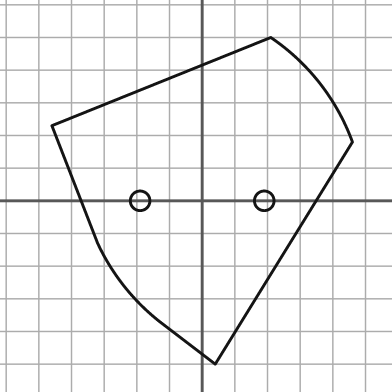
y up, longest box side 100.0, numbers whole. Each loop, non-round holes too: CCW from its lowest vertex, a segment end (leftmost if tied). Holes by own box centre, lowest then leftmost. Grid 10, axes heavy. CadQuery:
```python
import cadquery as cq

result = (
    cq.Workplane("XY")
    .moveTo(4.0, -50.0)
    .lineTo(46.0, 18.0)
    .threePointArc((36.0, 36.0), (21.0, 50.0))
    .lineTo(-46.0, 23.0)
    .lineTo(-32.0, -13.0)
    .threePointArc((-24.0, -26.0), (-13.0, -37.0))
    .close()
    .moveTo(-19.0, 0.0)
    .circle(3.0)
    .moveTo(19.0, 0.0)
    .circle(3.0)
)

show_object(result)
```